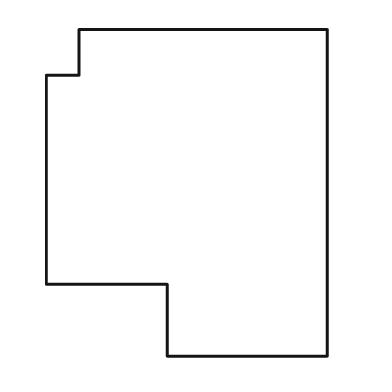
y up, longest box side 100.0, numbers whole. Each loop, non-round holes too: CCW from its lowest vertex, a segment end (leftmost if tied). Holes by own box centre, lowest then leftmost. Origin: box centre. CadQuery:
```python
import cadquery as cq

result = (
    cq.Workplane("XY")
    .moveTo(-6.0, -50.0)
    .lineTo(43.0, -50.0)
    .lineTo(43.0, 50.0)
    .lineTo(-33.0, 50.0)
    .lineTo(-33.0, 36.0)
    .lineTo(-43.0, 36.0)
    .lineTo(-43.0, -28.0)
    .lineTo(-6.0, -28.0)
    .close()
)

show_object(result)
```